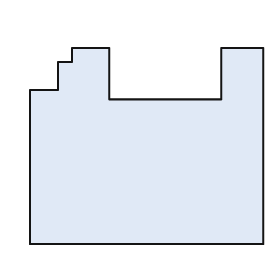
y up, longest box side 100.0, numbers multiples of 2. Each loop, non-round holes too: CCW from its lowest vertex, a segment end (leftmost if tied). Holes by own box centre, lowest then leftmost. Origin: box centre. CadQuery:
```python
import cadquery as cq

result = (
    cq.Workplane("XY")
    .moveTo(-50.0, -42.0)
    .lineTo(50.0, -42.0)
    .lineTo(50.0, 42.0)
    .lineTo(32.0, 42.0)
    .lineTo(32.0, 20.0)
    .lineTo(-16.0, 20.0)
    .lineTo(-16.0, 42.0)
    .lineTo(-32.0, 42.0)
    .lineTo(-32.0, 36.0)
    .lineTo(-38.0, 36.0)
    .lineTo(-38.0, 24.0)
    .lineTo(-50.0, 24.0)
    .close()
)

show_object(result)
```